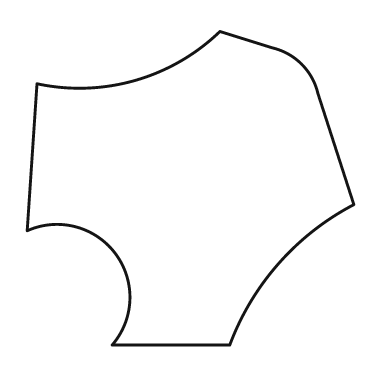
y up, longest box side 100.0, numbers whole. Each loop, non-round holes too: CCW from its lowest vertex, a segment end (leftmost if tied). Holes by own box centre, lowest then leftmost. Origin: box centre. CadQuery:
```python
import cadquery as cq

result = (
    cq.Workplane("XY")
    .moveTo(-24.0, -48.0)
    .lineTo(12.0, -48.0)
    .threePointArc((27.0, -23.0), (50.0, -5.0))
    .lineTo(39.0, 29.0)
    .threePointArc((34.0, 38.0), (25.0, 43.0))
    .lineTo(9.0, 48.0)
    .threePointArc((-17.0, 33.0), (-47.0, 32.0))
    .lineTo(-50.0, -13.0)
    .threePointArc((-23.0, -20.0), (-24.0, -48.0))
    .close()
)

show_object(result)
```